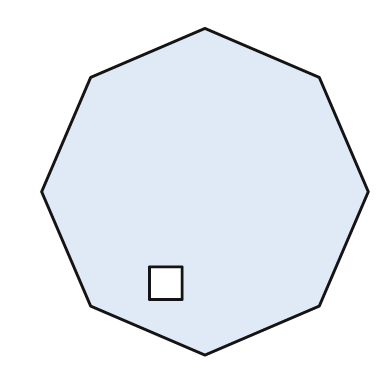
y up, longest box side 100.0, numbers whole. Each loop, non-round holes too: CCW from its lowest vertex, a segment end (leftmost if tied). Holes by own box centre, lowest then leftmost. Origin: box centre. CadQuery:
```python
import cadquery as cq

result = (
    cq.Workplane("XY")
    .moveTo(0.0, -50.0)
    .lineTo(35.0, -35.0)
    .lineTo(50.0, 0.0)
    .lineTo(35.0, 35.0)
    .lineTo(0.0, 50.0)
    .lineTo(-35.0, 35.0)
    .lineTo(-50.0, 0.0)
    .lineTo(-35.0, -35.0)
    .close()
    .moveTo(-17.0, -33.0)
    .lineTo(-7.0, -33.0)
    .lineTo(-7.0, -23.0)
    .lineTo(-17.0, -23.0)
    .close()
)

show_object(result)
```